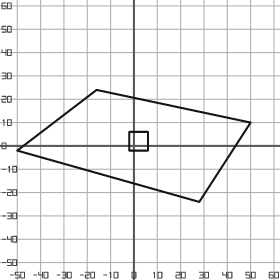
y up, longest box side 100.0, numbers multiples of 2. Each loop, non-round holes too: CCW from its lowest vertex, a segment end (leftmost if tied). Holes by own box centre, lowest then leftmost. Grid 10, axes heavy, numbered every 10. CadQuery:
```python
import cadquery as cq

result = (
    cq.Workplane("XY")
    .moveTo(28.0, -24.0)
    .lineTo(50.0, 10.0)
    .lineTo(-16.0, 24.0)
    .lineTo(-50.0, -2.0)
    .close()
    .moveTo(-2.0, -2.0)
    .lineTo(6.0, -2.0)
    .lineTo(6.0, 6.0)
    .lineTo(-2.0, 6.0)
    .close()
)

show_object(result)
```